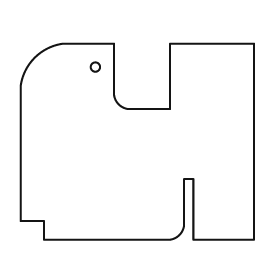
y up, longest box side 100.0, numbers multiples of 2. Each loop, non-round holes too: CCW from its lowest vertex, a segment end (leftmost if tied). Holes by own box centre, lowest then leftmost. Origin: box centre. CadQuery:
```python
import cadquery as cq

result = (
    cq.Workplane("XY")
    .moveTo(-40.0, -42.0)
    .lineTo(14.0, -42.0)
    .threePointArc((18.0, -40.0), (20.0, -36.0))
    .lineTo(20.0, -16.0)
    .lineTo(24.0, -16.0)
    .lineTo(24.0, -42.0)
    .lineTo(50.0, -42.0)
    .lineTo(50.0, 42.0)
    .lineTo(14.0, 42.0)
    .lineTo(14.0, 14.0)
    .lineTo(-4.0, 14.0)
    .threePointArc((-8.0, 16.0), (-10.0, 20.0))
    .lineTo(-10.0, 42.0)
    .lineTo(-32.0, 42.0)
    .threePointArc((-44.0, 36.0), (-50.0, 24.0))
    .lineTo(-50.0, -34.0)
    .lineTo(-40.0, -34.0)
    .close()
    .moveTo(-18.0, 32.0)
    .circle(2.0)
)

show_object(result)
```